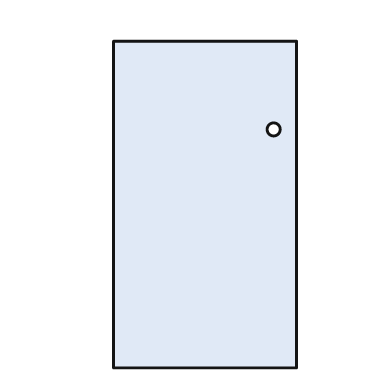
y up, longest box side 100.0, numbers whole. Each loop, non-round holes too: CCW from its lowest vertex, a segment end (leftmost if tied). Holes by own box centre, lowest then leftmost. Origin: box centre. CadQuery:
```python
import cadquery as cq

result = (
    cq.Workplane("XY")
    .moveTo(-28.0, -50.0)
    .lineTo(28.0, -50.0)
    .lineTo(28.0, 50.0)
    .lineTo(-28.0, 50.0)
    .close()
    .moveTo(21.0, 23.0)
    .circle(2.0)
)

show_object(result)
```